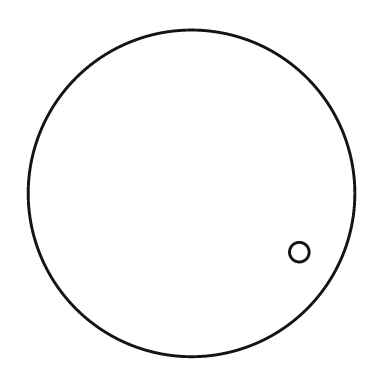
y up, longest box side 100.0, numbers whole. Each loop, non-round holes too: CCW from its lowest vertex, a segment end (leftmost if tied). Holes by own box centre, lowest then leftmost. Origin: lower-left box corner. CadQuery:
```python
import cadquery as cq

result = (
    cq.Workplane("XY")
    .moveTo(50.0, 50.0)
    .circle(50.0)
    .moveTo(83.0, 32.0)
    .circle(3.0)
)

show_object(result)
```